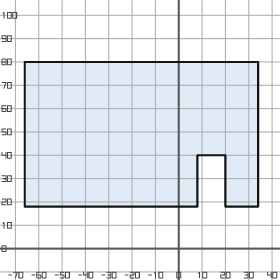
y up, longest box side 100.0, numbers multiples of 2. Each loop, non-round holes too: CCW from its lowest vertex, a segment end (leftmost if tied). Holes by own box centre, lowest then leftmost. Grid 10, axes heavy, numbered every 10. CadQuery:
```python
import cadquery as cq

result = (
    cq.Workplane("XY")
    .moveTo(-66.0, 18.0)
    .lineTo(8.0, 18.0)
    .lineTo(8.0, 40.0)
    .lineTo(20.0, 40.0)
    .lineTo(20.0, 18.0)
    .lineTo(34.0, 18.0)
    .lineTo(34.0, 80.0)
    .lineTo(-66.0, 80.0)
    .close()
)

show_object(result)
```